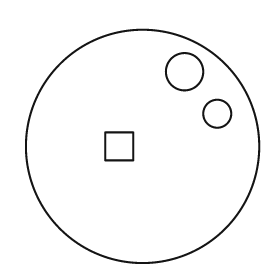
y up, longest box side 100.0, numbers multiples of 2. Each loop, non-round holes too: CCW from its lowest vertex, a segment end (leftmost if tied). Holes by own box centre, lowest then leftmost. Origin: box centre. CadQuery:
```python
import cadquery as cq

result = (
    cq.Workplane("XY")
    .moveTo(0.0, 0.0)
    .circle(50.0)
    .moveTo(-16.0, -6.0)
    .lineTo(-4.0, -6.0)
    .lineTo(-4.0, 6.0)
    .lineTo(-16.0, 6.0)
    .close()
    .moveTo(32.0, 14.0)
    .circle(6.0)
    .moveTo(18.0, 32.0)
    .circle(8.0)
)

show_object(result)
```